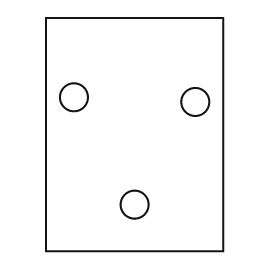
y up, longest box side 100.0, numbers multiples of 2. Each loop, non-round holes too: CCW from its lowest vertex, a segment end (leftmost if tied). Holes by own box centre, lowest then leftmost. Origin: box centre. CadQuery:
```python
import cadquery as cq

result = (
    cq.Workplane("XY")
    .moveTo(-38.0, -50.0)
    .lineTo(38.0, -50.0)
    .lineTo(38.0, 50.0)
    .lineTo(-38.0, 50.0)
    .close()
    .moveTo(0.0, -30.0)
    .circle(6.0)
    .moveTo(26.0, 14.0)
    .circle(6.0)
    .moveTo(-26.0, 16.0)
    .circle(6.0)
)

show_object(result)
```